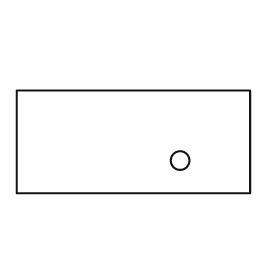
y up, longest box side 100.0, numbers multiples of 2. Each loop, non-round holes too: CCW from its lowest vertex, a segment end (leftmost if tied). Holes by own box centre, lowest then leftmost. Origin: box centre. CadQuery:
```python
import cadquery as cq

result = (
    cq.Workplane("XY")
    .moveTo(-50.0, -22.0)
    .lineTo(50.0, -22.0)
    .lineTo(50.0, 22.0)
    .lineTo(-50.0, 22.0)
    .close()
    .moveTo(20.0, -8.0)
    .circle(4.0)
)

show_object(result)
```